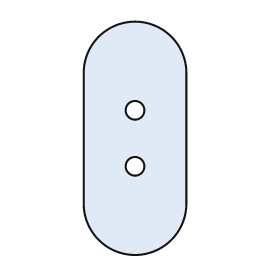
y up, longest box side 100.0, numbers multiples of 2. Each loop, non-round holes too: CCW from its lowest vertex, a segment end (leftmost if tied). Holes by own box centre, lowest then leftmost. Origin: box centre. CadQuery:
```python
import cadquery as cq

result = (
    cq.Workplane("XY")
    .moveTo(-22.0, -28.0)
    .threePointArc((0.0, -50.0), (22.0, -28.0))
    .lineTo(22.0, 28.0)
    .threePointArc((0.0, 50.0), (-22.0, 28.0))
    .close()
    .moveTo(0.0, -12.0)
    .circle(4.0)
    .moveTo(0.0, 12.0)
    .circle(4.0)
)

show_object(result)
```